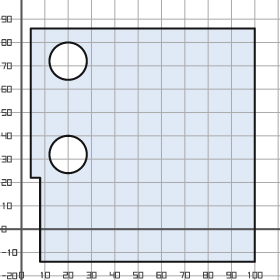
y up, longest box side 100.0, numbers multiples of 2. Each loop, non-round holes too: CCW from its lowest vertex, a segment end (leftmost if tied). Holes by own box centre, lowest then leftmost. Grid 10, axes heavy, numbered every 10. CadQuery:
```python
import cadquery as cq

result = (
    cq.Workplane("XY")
    .moveTo(8.0, -14.0)
    .lineTo(100.0, -14.0)
    .lineTo(100.0, 86.0)
    .lineTo(4.0, 86.0)
    .lineTo(4.0, 22.0)
    .lineTo(8.0, 22.0)
    .close()
    .moveTo(20.0, 32.0)
    .circle(8.0)
    .moveTo(20.0, 72.0)
    .circle(8.0)
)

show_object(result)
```